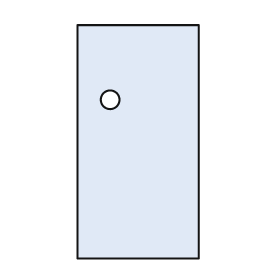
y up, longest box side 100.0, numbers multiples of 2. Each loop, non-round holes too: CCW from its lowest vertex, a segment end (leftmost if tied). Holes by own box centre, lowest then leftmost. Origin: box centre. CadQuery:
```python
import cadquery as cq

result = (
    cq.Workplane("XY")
    .moveTo(-26.0, -50.0)
    .lineTo(26.0, -50.0)
    .lineTo(26.0, 50.0)
    .lineTo(-26.0, 50.0)
    .close()
    .moveTo(-12.0, 18.0)
    .circle(4.0)
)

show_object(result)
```